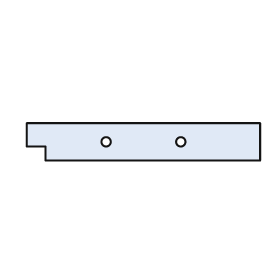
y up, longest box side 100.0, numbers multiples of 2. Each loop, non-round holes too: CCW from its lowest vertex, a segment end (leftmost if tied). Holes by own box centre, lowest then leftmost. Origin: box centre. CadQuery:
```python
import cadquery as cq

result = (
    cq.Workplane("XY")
    .moveTo(-42.0, -8.0)
    .lineTo(50.0, -8.0)
    .lineTo(50.0, 8.0)
    .lineTo(-50.0, 8.0)
    .lineTo(-50.0, -2.0)
    .lineTo(-42.0, -2.0)
    .close()
    .moveTo(-16.0, 0.0)
    .circle(2.0)
    .moveTo(16.0, 0.0)
    .circle(2.0)
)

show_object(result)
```